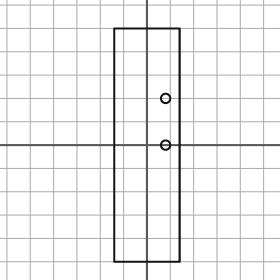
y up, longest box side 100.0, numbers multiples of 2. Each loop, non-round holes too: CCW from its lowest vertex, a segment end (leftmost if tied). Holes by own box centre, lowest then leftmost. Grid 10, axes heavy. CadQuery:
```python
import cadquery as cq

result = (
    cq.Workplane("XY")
    .moveTo(-14.0, -50.0)
    .lineTo(14.0, -50.0)
    .lineTo(14.0, 50.0)
    .lineTo(-14.0, 50.0)
    .close()
    .moveTo(8.0, 0.0)
    .circle(2.0)
    .moveTo(8.0, 20.0)
    .circle(2.0)
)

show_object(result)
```